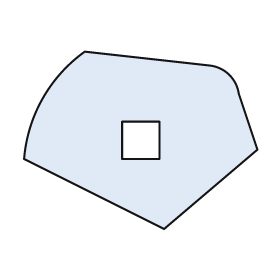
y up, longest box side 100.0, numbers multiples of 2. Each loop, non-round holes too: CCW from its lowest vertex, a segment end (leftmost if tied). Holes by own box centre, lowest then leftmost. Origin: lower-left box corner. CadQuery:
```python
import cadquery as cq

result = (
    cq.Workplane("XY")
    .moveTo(60.0, 0.0)
    .lineTo(100.0, 34.0)
    .lineTo(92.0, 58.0)
    .threePointArc((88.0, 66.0), (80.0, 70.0))
    .lineTo(26.0, 76.0)
    .threePointArc((8.0, 56.0), (0.0, 30.0))
    .close()
    .moveTo(42.0, 30.0)
    .lineTo(58.0, 30.0)
    .lineTo(58.0, 46.0)
    .lineTo(42.0, 46.0)
    .close()
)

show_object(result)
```